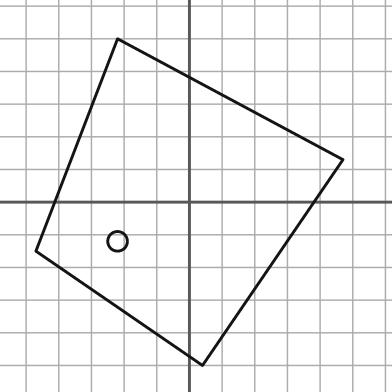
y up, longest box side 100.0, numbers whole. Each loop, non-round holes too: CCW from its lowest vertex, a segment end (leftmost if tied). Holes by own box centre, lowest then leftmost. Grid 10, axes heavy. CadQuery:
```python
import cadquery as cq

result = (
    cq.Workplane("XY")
    .moveTo(4.0, -50.0)
    .lineTo(47.0, 13.0)
    .lineTo(-22.0, 50.0)
    .lineTo(-47.0, -15.0)
    .close()
    .moveTo(-22.0, -12.0)
    .circle(3.0)
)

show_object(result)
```